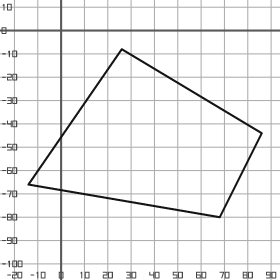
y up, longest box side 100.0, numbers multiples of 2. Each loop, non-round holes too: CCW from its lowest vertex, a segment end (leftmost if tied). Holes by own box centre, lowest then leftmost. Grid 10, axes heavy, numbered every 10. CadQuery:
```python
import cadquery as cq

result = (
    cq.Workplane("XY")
    .moveTo(68.0, -80.0)
    .lineTo(86.0, -44.0)
    .lineTo(26.0, -8.0)
    .lineTo(-14.0, -66.0)
    .close()
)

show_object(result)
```